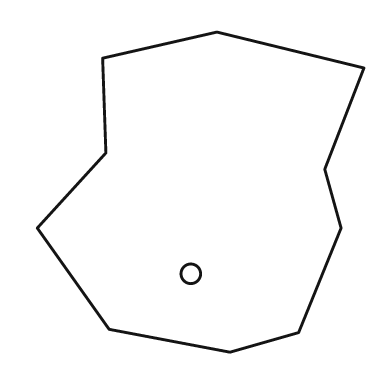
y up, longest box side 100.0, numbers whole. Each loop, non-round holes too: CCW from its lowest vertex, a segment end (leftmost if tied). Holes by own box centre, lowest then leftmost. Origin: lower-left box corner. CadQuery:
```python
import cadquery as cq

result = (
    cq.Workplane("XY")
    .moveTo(59.0, 0.0)
    .lineTo(80.0, 6.0)
    .lineTo(93.0, 38.0)
    .lineTo(88.0, 56.0)
    .lineTo(100.0, 87.0)
    .lineTo(55.0, 98.0)
    .lineTo(20.0, 90.0)
    .lineTo(21.0, 61.0)
    .lineTo(0.0, 38.0)
    .lineTo(22.0, 7.0)
    .close()
    .moveTo(47.0, 24.0)
    .circle(3.0)
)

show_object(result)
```